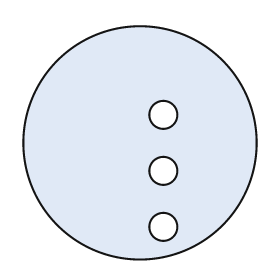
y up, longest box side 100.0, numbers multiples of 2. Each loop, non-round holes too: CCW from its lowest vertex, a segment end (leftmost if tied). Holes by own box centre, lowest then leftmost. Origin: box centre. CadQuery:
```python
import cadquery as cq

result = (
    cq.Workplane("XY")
    .moveTo(0.0, 0.0)
    .circle(50.0)
    .moveTo(10.0, -36.0)
    .circle(6.0)
    .moveTo(10.0, -12.0)
    .circle(6.0)
    .moveTo(10.0, 12.0)
    .circle(6.0)
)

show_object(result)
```